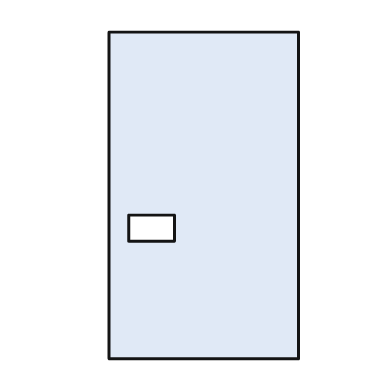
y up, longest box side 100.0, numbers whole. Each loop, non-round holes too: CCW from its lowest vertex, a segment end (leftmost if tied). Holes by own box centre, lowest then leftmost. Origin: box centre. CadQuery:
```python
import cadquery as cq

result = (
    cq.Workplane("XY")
    .moveTo(-29.0, -50.0)
    .lineTo(29.0, -50.0)
    .lineTo(29.0, 50.0)
    .lineTo(-29.0, 50.0)
    .close()
    .moveTo(-23.0, -14.0)
    .lineTo(-9.0, -14.0)
    .lineTo(-9.0, -6.0)
    .lineTo(-23.0, -6.0)
    .close()
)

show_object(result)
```